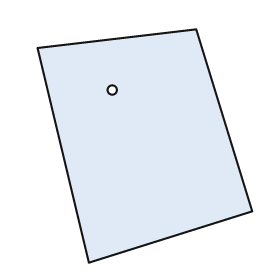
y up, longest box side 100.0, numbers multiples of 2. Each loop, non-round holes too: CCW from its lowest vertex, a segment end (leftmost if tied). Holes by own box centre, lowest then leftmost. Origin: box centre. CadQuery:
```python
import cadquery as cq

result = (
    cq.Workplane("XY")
    .moveTo(-24.0, -50.0)
    .lineTo(46.0, -28.0)
    .lineTo(22.0, 50.0)
    .lineTo(-46.0, 42.0)
    .close()
    .moveTo(-14.0, 24.0)
    .circle(2.0)
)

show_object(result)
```